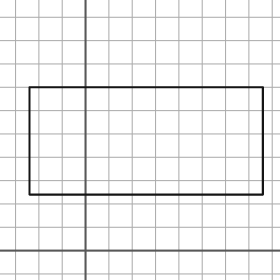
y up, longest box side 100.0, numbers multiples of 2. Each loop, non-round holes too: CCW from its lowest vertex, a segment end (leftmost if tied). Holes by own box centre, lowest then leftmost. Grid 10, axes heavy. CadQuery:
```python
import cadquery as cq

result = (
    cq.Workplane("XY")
    .moveTo(-24.0, 24.0)
    .lineTo(76.0, 24.0)
    .lineTo(76.0, 70.0)
    .lineTo(-24.0, 70.0)
    .close()
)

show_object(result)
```